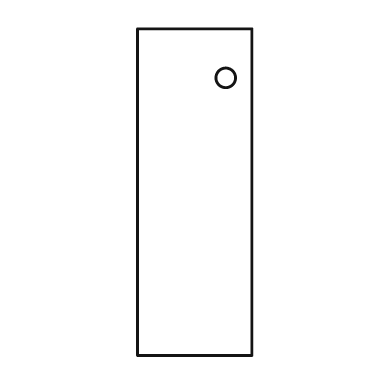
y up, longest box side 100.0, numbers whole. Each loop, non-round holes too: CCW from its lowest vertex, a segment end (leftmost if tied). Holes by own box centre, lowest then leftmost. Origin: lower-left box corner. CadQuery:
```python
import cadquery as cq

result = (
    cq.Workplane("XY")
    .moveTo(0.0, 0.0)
    .lineTo(35.0, 0.0)
    .lineTo(35.0, 100.0)
    .lineTo(0.0, 100.0)
    .close()
    .moveTo(27.0, 85.0)
    .circle(3.0)
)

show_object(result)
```